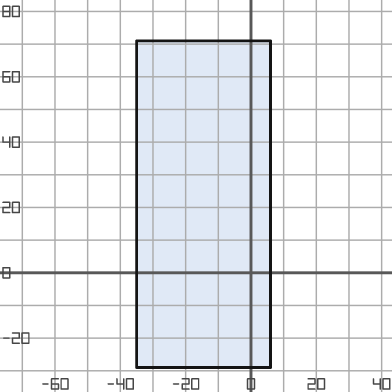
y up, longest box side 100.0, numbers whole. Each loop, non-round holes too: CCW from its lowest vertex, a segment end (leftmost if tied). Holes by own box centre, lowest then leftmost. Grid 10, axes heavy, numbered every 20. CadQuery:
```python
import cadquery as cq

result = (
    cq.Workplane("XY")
    .moveTo(-35.0, -29.0)
    .lineTo(6.0, -29.0)
    .lineTo(6.0, 71.0)
    .lineTo(-35.0, 71.0)
    .close()
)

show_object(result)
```